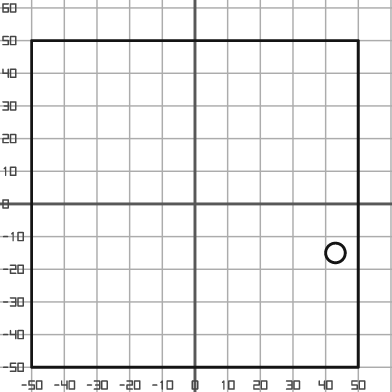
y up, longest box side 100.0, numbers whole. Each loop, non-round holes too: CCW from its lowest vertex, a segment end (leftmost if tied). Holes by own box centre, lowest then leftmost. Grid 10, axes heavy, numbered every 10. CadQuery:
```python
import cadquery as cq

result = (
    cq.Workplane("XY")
    .moveTo(-50.0, -50.0)
    .lineTo(50.0, -50.0)
    .lineTo(50.0, 50.0)
    .lineTo(-50.0, 50.0)
    .close()
    .moveTo(43.0, -15.0)
    .circle(3.0)
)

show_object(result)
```